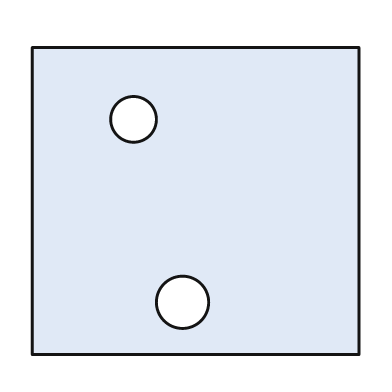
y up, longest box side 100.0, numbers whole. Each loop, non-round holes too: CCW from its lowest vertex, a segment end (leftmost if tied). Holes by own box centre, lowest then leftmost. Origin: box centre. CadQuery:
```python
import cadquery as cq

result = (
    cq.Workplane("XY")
    .moveTo(-50.0, -47.0)
    .lineTo(50.0, -47.0)
    .lineTo(50.0, 47.0)
    .lineTo(-50.0, 47.0)
    .close()
    .moveTo(-4.0, -31.0)
    .circle(8.0)
    .moveTo(-19.0, 25.0)
    .circle(7.0)
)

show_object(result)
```